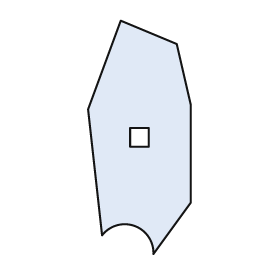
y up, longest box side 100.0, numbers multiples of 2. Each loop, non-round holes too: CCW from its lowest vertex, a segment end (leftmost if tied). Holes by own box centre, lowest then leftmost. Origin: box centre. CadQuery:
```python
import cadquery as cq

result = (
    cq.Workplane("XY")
    .moveTo(6.0, -50.0)
    .lineTo(22.0, -28.0)
    .lineTo(22.0, 14.0)
    .lineTo(16.0, 40.0)
    .lineTo(-8.0, 50.0)
    .lineTo(-22.0, 12.0)
    .lineTo(-16.0, -42.0)
    .threePointArc((-2.0, -38.0), (6.0, -50.0))
    .close()
    .moveTo(-4.0, -4.0)
    .lineTo(4.0, -4.0)
    .lineTo(4.0, 4.0)
    .lineTo(-4.0, 4.0)
    .close()
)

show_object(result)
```